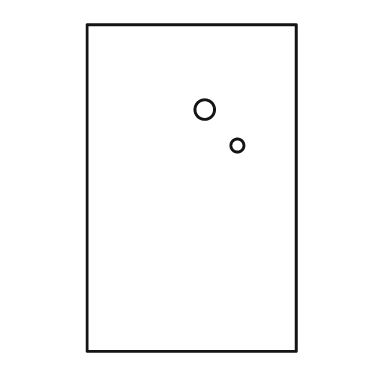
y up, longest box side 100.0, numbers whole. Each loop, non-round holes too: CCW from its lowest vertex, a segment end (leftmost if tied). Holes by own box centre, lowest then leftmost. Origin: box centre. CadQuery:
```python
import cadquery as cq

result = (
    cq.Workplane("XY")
    .moveTo(-32.0, -50.0)
    .lineTo(32.0, -50.0)
    .lineTo(32.0, 50.0)
    .lineTo(-32.0, 50.0)
    .close()
    .moveTo(14.0, 13.0)
    .circle(2.0)
    .moveTo(4.0, 24.0)
    .circle(3.0)
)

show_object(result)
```